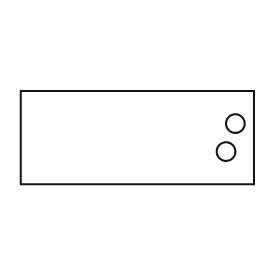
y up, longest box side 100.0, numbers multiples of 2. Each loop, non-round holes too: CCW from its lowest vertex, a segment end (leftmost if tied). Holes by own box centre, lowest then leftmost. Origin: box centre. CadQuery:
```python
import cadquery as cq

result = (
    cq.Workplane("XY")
    .moveTo(-50.0, -20.0)
    .lineTo(50.0, -20.0)
    .lineTo(50.0, 20.0)
    .lineTo(-50.0, 20.0)
    .close()
    .moveTo(38.0, -6.0)
    .circle(4.0)
    .moveTo(42.0, 6.0)
    .circle(4.0)
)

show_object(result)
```